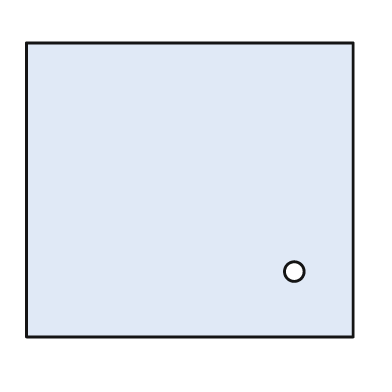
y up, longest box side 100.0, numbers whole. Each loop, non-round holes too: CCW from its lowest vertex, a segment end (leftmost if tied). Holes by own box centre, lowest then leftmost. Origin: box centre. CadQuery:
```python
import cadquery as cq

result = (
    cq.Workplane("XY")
    .moveTo(-50.0, -45.0)
    .lineTo(50.0, -45.0)
    .lineTo(50.0, 45.0)
    .lineTo(-50.0, 45.0)
    .close()
    .moveTo(32.0, -25.0)
    .circle(3.0)
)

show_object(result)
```